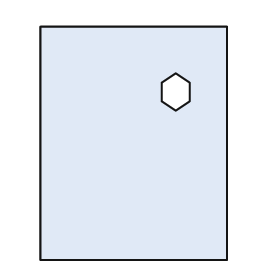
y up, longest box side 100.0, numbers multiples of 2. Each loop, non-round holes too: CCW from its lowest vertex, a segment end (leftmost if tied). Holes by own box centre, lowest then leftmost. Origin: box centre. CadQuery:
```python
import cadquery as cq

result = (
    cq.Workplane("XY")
    .moveTo(-40.0, -50.0)
    .lineTo(40.0, -50.0)
    .lineTo(40.0, 50.0)
    .lineTo(-40.0, 50.0)
    .close()
    .moveTo(18.0, 14.0)
    .lineTo(24.0, 18.0)
    .lineTo(24.0, 26.0)
    .lineTo(18.0, 30.0)
    .lineTo(12.0, 26.0)
    .lineTo(12.0, 18.0)
    .close()
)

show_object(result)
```